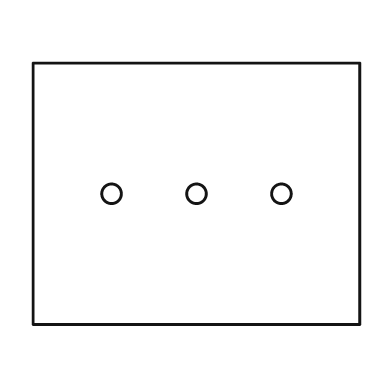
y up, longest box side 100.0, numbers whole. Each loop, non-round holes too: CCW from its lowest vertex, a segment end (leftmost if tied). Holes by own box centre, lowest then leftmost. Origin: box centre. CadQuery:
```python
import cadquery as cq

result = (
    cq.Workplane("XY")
    .moveTo(-50.0, -40.0)
    .lineTo(50.0, -40.0)
    .lineTo(50.0, 40.0)
    .lineTo(-50.0, 40.0)
    .close()
    .moveTo(-26.0, 0.0)
    .circle(3.0)
    .moveTo(0.0, 0.0)
    .circle(3.0)
    .moveTo(26.0, 0.0)
    .circle(3.0)
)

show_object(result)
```